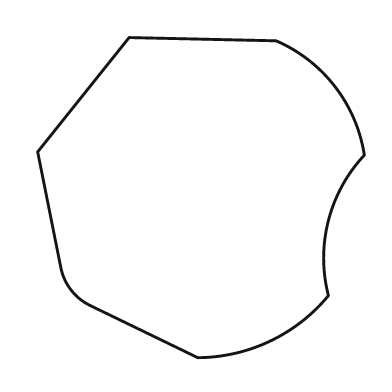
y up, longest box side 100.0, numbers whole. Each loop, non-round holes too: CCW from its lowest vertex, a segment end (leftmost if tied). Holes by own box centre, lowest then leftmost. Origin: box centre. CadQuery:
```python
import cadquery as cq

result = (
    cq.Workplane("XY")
    .moveTo(-1.0, -49.0)
    .threePointArc((21.0, -44.0), (39.0, -30.0))
    .threePointArc((39.0, -7.0), (50.0, 13.0))
    .threePointArc((41.0, 34.0), (23.0, 48.0))
    .lineTo(-22.0, 49.0)
    .lineTo(-50.0, 14.0)
    .lineTo(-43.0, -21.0)
    .threePointArc((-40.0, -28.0), (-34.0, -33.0))
    .close()
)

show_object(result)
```